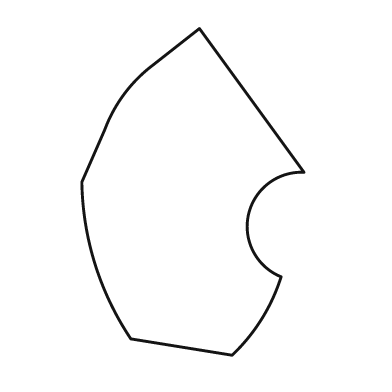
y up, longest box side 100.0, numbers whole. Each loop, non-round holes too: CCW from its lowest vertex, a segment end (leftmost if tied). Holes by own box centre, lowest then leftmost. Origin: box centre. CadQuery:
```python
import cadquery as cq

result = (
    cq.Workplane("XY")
    .moveTo(12.0, -50.0)
    .threePointArc((21.0, -39.0), (27.0, -26.0))
    .threePointArc((17.0, -7.0), (34.0, 6.0))
    .lineTo(2.0, 50.0)
    .lineTo(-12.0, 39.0)
    .threePointArc((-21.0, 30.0), (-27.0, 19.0))
    .lineTo(-34.0, 3.0)
    .threePointArc((-30.0, -22.0), (-19.0, -45.0))
    .close()
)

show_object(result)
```